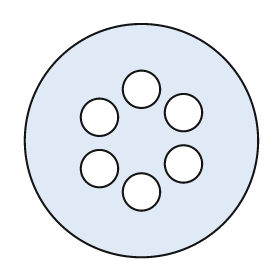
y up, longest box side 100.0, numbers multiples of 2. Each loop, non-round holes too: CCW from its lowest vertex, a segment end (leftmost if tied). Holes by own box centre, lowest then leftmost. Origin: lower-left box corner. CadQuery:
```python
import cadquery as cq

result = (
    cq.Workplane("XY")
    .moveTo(50.0, 50.0)
    .circle(50.0)
    .moveTo(50.0, 28.0)
    .circle(8.0)
    .moveTo(32.0, 38.0)
    .circle(8.0)
    .moveTo(68.0, 40.0)
    .circle(8.0)
    .moveTo(32.0, 60.0)
    .circle(8.0)
    .moveTo(68.0, 62.0)
    .circle(8.0)
    .moveTo(50.0, 72.0)
    .circle(8.0)
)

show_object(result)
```